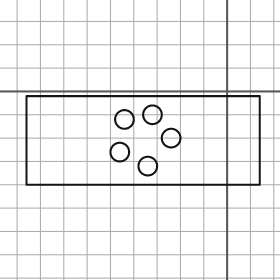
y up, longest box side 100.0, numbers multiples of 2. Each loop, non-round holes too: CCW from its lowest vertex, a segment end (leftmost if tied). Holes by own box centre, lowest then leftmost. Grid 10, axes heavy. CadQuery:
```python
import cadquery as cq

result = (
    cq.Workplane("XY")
    .moveTo(-86.0, -40.0)
    .lineTo(14.0, -40.0)
    .lineTo(14.0, -2.0)
    .lineTo(-86.0, -2.0)
    .close()
    .moveTo(-34.0, -32.0)
    .circle(4.0)
    .moveTo(-46.0, -26.0)
    .circle(4.0)
    .moveTo(-24.0, -20.0)
    .circle(4.0)
    .moveTo(-44.0, -12.0)
    .circle(4.0)
    .moveTo(-32.0, -10.0)
    .circle(4.0)
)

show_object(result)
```